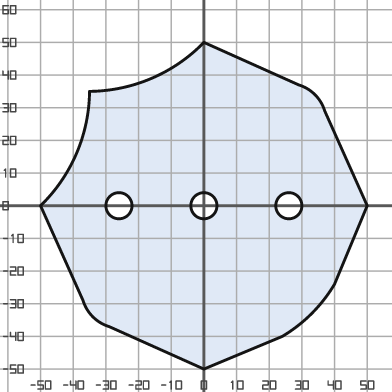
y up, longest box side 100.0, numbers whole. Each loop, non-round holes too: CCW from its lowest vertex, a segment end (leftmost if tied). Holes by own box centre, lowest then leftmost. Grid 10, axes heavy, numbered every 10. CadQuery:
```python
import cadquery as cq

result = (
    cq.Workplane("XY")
    .moveTo(0.0, -50.0)
    .lineTo(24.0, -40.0)
    .threePointArc((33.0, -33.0), (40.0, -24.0))
    .lineTo(50.0, 0.0)
    .lineTo(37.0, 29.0)
    .threePointArc((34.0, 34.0), (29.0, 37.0))
    .lineTo(0.0, 50.0)
    .threePointArc((-16.0, 39.0), (-35.0, 35.0))
    .threePointArc((-39.0, 16.0), (-50.0, 0.0))
    .lineTo(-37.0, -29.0)
    .threePointArc((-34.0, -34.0), (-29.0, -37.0))
    .close()
    .moveTo(-26.0, 0.0)
    .circle(4.0)
    .moveTo(0.0, 0.0)
    .circle(4.0)
    .moveTo(26.0, 0.0)
    .circle(4.0)
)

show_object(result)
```